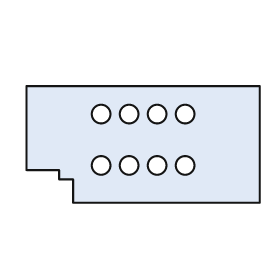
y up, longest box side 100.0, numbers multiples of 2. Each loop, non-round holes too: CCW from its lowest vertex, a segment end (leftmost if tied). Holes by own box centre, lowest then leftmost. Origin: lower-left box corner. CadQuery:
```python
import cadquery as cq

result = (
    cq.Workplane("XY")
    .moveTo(20.0, 0.0)
    .lineTo(100.0, 0.0)
    .lineTo(100.0, 50.0)
    .lineTo(0.0, 50.0)
    .lineTo(0.0, 14.0)
    .lineTo(14.0, 14.0)
    .lineTo(14.0, 10.0)
    .lineTo(20.0, 10.0)
    .close()
    .moveTo(32.0, 16.0)
    .circle(4.0)
    .moveTo(44.0, 16.0)
    .circle(4.0)
    .moveTo(56.0, 16.0)
    .circle(4.0)
    .moveTo(68.0, 16.0)
    .circle(4.0)
    .moveTo(32.0, 38.0)
    .circle(4.0)
    .moveTo(44.0, 38.0)
    .circle(4.0)
    .moveTo(56.0, 38.0)
    .circle(4.0)
    .moveTo(68.0, 38.0)
    .circle(4.0)
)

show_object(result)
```